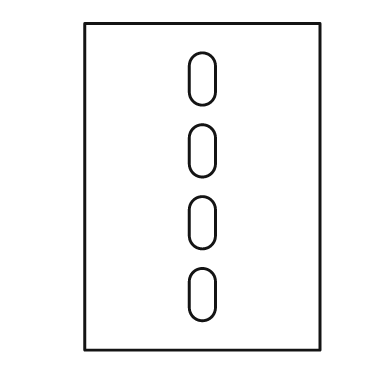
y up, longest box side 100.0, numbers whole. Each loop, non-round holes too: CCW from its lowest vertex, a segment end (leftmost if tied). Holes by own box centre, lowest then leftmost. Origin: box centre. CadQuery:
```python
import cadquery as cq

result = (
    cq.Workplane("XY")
    .moveTo(-36.0, -50.0)
    .lineTo(36.0, -50.0)
    .lineTo(36.0, 50.0)
    .lineTo(-36.0, 50.0)
    .close()
    .moveTo(-4.0, -37.0)
    .threePointArc((0.0, -41.0), (4.0, -37.0))
    .lineTo(4.0, -29.0)
    .threePointArc((0.0, -25.0), (-4.0, -29.0))
    .close()
    .moveTo(-4.0, -15.0)
    .threePointArc((0.0, -19.0), (4.0, -15.0))
    .lineTo(4.0, -7.0)
    .threePointArc((0.0, -3.0), (-4.0, -7.0))
    .close()
    .moveTo(-4.0, 7.0)
    .threePointArc((0.0, 3.0), (4.0, 7.0))
    .lineTo(4.0, 15.0)
    .threePointArc((0.0, 19.0), (-4.0, 15.0))
    .close()
    .moveTo(-4.0, 29.0)
    .threePointArc((0.0, 25.0), (4.0, 29.0))
    .lineTo(4.0, 37.0)
    .threePointArc((0.0, 41.0), (-4.0, 37.0))
    .close()
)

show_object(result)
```